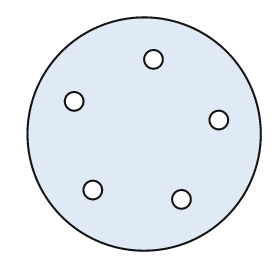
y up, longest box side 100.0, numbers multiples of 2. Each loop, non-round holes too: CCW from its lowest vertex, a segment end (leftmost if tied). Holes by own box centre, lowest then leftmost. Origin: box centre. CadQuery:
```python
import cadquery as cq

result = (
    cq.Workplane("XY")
    .moveTo(0.0, 0.0)
    .circle(50.0)
    .moveTo(16.0, -28.0)
    .circle(4.0)
    .moveTo(-22.0, -24.0)
    .circle(4.0)
    .moveTo(32.0, 6.0)
    .circle(4.0)
    .moveTo(-30.0, 14.0)
    .circle(4.0)
    .moveTo(4.0, 32.0)
    .circle(4.0)
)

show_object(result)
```